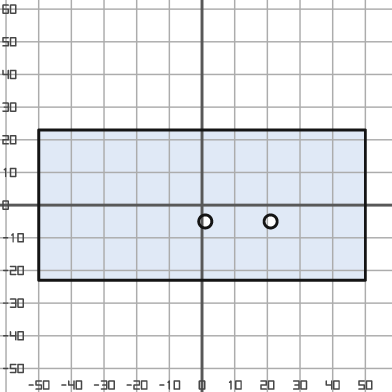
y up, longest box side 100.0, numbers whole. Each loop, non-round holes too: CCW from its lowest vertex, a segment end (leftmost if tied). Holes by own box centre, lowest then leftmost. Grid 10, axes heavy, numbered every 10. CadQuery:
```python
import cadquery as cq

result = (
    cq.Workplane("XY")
    .moveTo(-50.0, -23.0)
    .lineTo(50.0, -23.0)
    .lineTo(50.0, 23.0)
    .lineTo(-50.0, 23.0)
    .close()
    .moveTo(1.0, -5.0)
    .circle(2.0)
    .moveTo(21.0, -5.0)
    .circle(2.0)
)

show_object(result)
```